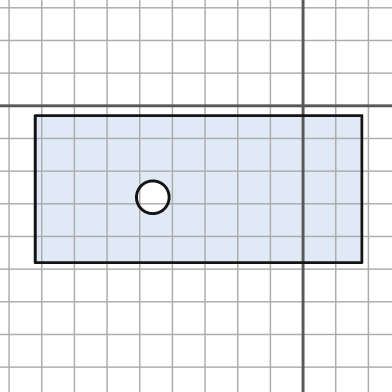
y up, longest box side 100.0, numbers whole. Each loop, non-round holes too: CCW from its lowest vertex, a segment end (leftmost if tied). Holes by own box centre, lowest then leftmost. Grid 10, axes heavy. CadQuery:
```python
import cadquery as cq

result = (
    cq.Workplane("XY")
    .moveTo(-82.0, -48.0)
    .lineTo(18.0, -48.0)
    .lineTo(18.0, -3.0)
    .lineTo(-82.0, -3.0)
    .close()
    .moveTo(-46.0, -28.0)
    .circle(5.0)
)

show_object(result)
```